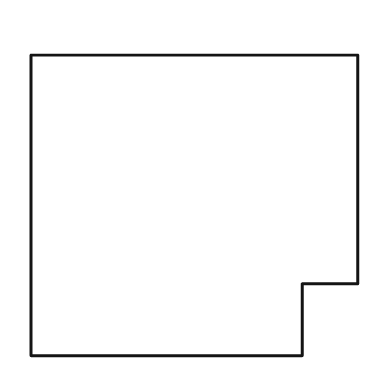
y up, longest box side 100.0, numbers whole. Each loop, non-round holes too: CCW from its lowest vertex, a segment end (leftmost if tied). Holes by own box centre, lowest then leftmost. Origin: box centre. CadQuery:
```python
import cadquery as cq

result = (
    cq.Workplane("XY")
    .moveTo(-50.0, -46.0)
    .lineTo(33.0, -46.0)
    .lineTo(33.0, -24.0)
    .lineTo(50.0, -24.0)
    .lineTo(50.0, 46.0)
    .lineTo(-50.0, 46.0)
    .close()
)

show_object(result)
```